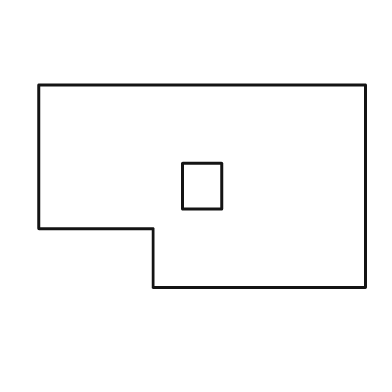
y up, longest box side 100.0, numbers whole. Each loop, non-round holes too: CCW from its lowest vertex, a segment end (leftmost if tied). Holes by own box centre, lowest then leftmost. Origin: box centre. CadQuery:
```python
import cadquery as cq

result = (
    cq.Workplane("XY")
    .moveTo(-15.0, -31.0)
    .lineTo(50.0, -31.0)
    .lineTo(50.0, 31.0)
    .lineTo(-50.0, 31.0)
    .lineTo(-50.0, -13.0)
    .lineTo(-15.0, -13.0)
    .close()
    .moveTo(-6.0, -7.0)
    .lineTo(6.0, -7.0)
    .lineTo(6.0, 7.0)
    .lineTo(-6.0, 7.0)
    .close()
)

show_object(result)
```